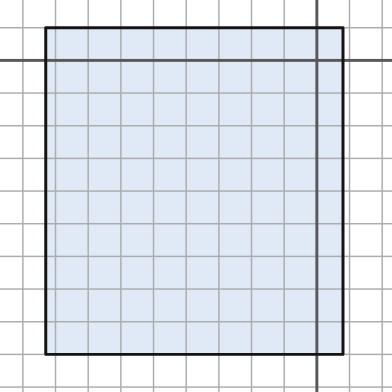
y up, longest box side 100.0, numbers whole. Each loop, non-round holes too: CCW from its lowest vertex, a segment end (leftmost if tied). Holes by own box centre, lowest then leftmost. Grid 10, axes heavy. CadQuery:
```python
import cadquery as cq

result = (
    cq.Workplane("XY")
    .moveTo(-83.0, -90.0)
    .lineTo(8.0, -90.0)
    .lineTo(8.0, 10.0)
    .lineTo(-83.0, 10.0)
    .close()
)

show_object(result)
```